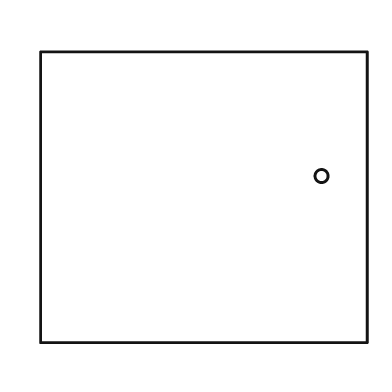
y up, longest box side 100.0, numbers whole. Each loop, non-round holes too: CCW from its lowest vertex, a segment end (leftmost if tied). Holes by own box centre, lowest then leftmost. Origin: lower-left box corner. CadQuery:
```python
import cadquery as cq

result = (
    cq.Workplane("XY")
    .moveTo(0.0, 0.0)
    .lineTo(100.0, 0.0)
    .lineTo(100.0, 89.0)
    .lineTo(0.0, 89.0)
    .close()
    .moveTo(86.0, 51.0)
    .circle(2.0)
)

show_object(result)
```